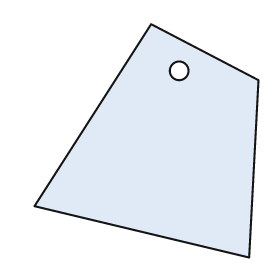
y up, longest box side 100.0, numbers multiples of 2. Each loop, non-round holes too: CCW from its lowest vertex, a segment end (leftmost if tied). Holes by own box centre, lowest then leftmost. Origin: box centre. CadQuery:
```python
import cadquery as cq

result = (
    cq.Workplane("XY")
    .moveTo(44.0, -50.0)
    .lineTo(48.0, 26.0)
    .lineTo(2.0, 50.0)
    .lineTo(-48.0, -28.0)
    .close()
    .moveTo(14.0, 30.0)
    .circle(4.0)
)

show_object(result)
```